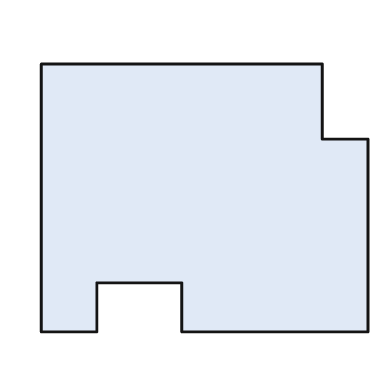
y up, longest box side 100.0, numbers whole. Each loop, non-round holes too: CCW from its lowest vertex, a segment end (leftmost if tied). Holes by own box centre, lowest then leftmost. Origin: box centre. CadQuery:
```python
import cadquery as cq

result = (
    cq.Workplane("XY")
    .moveTo(-50.0, -41.0)
    .lineTo(-33.0, -41.0)
    .lineTo(-33.0, -26.0)
    .lineTo(-7.0, -26.0)
    .lineTo(-7.0, -41.0)
    .lineTo(50.0, -41.0)
    .lineTo(50.0, 18.0)
    .lineTo(36.0, 18.0)
    .lineTo(36.0, 41.0)
    .lineTo(-50.0, 41.0)
    .close()
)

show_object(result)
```